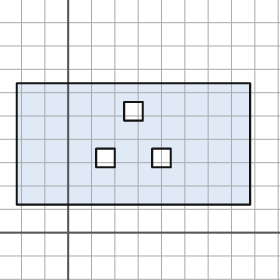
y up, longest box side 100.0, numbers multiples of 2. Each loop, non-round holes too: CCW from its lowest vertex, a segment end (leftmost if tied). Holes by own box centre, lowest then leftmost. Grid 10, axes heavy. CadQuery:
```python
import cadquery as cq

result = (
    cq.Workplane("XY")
    .moveTo(-22.0, 12.0)
    .lineTo(78.0, 12.0)
    .lineTo(78.0, 64.0)
    .lineTo(-22.0, 64.0)
    .close()
    .moveTo(12.0, 28.0)
    .lineTo(20.0, 28.0)
    .lineTo(20.0, 36.0)
    .lineTo(12.0, 36.0)
    .close()
    .moveTo(36.0, 28.0)
    .lineTo(44.0, 28.0)
    .lineTo(44.0, 36.0)
    .lineTo(36.0, 36.0)
    .close()
    .moveTo(24.0, 48.0)
    .lineTo(32.0, 48.0)
    .lineTo(32.0, 56.0)
    .lineTo(24.0, 56.0)
    .close()
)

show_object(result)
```